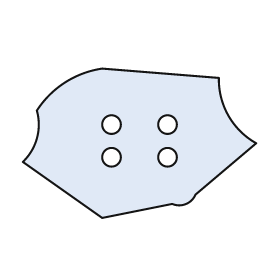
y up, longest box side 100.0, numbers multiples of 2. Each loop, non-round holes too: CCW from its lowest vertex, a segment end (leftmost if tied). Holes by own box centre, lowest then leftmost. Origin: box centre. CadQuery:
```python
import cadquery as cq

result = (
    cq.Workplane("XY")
    .moveTo(-16.0, -32.0)
    .lineTo(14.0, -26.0)
    .threePointArc((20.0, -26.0), (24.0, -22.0))
    .lineTo(50.0, 0.0)
    .threePointArc((38.0, 12.0), (34.0, 28.0))
    .lineTo(-16.0, 32.0)
    .threePointArc((-32.0, 26.0), (-44.0, 14.0))
    .threePointArc((-44.0, 2.0), (-50.0, -8.0))
    .close()
    .moveTo(-12.0, -6.0)
    .circle(4.0)
    .moveTo(12.0, -6.0)
    .circle(4.0)
    .moveTo(-12.0, 8.0)
    .circle(4.0)
    .moveTo(12.0, 8.0)
    .circle(4.0)
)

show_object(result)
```